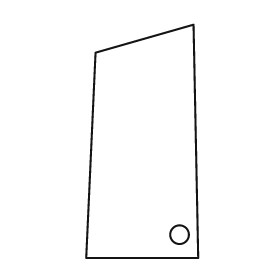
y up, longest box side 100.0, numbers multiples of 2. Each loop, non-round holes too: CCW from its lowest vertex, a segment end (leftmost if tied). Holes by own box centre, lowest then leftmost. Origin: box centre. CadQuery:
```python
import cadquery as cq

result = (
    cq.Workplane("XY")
    .moveTo(-24.0, -50.0)
    .lineTo(24.0, -50.0)
    .lineTo(22.0, 50.0)
    .lineTo(-20.0, 38.0)
    .close()
    .moveTo(16.0, -40.0)
    .circle(4.0)
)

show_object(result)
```